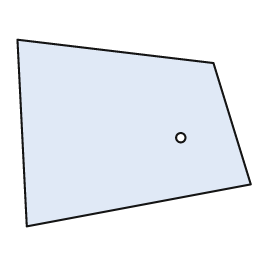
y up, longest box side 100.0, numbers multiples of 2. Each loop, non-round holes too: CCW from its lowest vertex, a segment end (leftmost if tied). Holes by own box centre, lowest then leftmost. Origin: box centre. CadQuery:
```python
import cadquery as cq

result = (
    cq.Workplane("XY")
    .moveTo(-46.0, -40.0)
    .lineTo(50.0, -22.0)
    .lineTo(34.0, 30.0)
    .lineTo(-50.0, 40.0)
    .close()
    .moveTo(20.0, -2.0)
    .circle(2.0)
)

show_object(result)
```